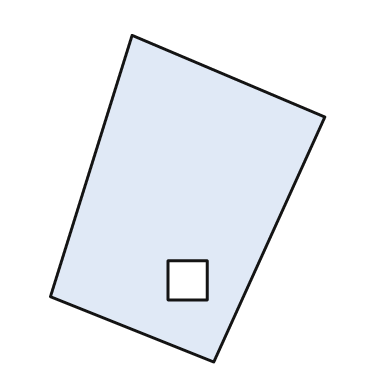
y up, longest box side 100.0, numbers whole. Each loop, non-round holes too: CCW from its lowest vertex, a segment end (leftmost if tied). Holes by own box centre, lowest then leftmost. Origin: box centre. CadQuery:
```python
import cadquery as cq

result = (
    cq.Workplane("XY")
    .moveTo(8.0, -50.0)
    .lineTo(42.0, 25.0)
    .lineTo(-17.0, 50.0)
    .lineTo(-42.0, -30.0)
    .close()
    .moveTo(-6.0, -31.0)
    .lineTo(6.0, -31.0)
    .lineTo(6.0, -19.0)
    .lineTo(-6.0, -19.0)
    .close()
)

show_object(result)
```